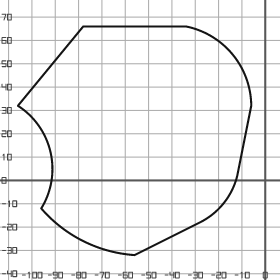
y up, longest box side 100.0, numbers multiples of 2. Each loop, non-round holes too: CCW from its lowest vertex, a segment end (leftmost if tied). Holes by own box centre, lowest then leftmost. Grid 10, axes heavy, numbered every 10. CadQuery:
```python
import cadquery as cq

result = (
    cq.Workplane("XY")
    .moveTo(-56.0, -32.0)
    .lineTo(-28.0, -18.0)
    .threePointArc((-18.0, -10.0), (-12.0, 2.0))
    .lineTo(-6.0, 32.0)
    .threePointArc((-14.0, 54.0), (-34.0, 66.0))
    .lineTo(-78.0, 66.0)
    .lineTo(-106.0, 32.0)
    .threePointArc((-92.0, 12.0), (-96.0, -12.0))
    .threePointArc((-78.0, -26.0), (-56.0, -32.0))
    .close()
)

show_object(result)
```